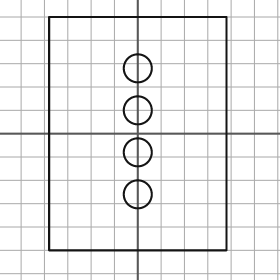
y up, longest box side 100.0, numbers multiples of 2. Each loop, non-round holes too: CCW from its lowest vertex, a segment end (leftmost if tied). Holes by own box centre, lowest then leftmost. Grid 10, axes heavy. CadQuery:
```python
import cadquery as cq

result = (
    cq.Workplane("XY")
    .moveTo(-38.0, -50.0)
    .lineTo(38.0, -50.0)
    .lineTo(38.0, 50.0)
    .lineTo(-38.0, 50.0)
    .close()
    .moveTo(0.0, -26.0)
    .circle(6.0)
    .moveTo(0.0, -8.0)
    .circle(6.0)
    .moveTo(0.0, 10.0)
    .circle(6.0)
    .moveTo(0.0, 28.0)
    .circle(6.0)
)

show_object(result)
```